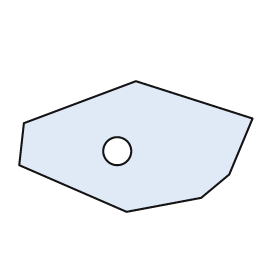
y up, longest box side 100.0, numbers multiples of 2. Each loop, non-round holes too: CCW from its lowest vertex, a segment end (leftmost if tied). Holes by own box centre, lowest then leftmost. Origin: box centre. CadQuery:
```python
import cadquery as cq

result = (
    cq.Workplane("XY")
    .moveTo(-4.0, -28.0)
    .lineTo(28.0, -22.0)
    .lineTo(40.0, -12.0)
    .lineTo(50.0, 12.0)
    .lineTo(0.0, 28.0)
    .lineTo(-48.0, 10.0)
    .lineTo(-50.0, -8.0)
    .close()
    .moveTo(-8.0, -2.0)
    .circle(6.0)
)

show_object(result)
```